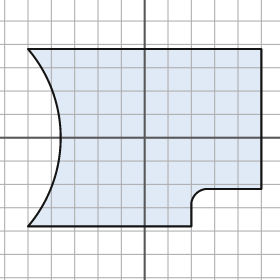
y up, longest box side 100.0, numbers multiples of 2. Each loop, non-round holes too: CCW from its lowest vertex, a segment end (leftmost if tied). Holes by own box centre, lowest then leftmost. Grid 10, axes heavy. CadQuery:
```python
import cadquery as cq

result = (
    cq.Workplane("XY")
    .moveTo(-50.0, -38.0)
    .lineTo(20.0, -38.0)
    .lineTo(20.0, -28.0)
    .threePointArc((22.0, -24.0), (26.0, -22.0))
    .lineTo(50.0, -22.0)
    .lineTo(50.0, 38.0)
    .lineTo(-50.0, 38.0)
    .threePointArc((-36.0, 0.0), (-50.0, -38.0))
    .close()
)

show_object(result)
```